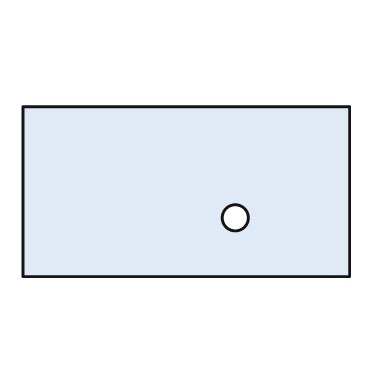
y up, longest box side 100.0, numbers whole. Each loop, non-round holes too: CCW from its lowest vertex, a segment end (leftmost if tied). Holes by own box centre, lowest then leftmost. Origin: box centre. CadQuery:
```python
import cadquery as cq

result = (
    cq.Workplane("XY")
    .moveTo(-50.0, -26.0)
    .lineTo(50.0, -26.0)
    .lineTo(50.0, 26.0)
    .lineTo(-50.0, 26.0)
    .close()
    .moveTo(15.0, -8.0)
    .circle(4.0)
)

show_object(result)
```